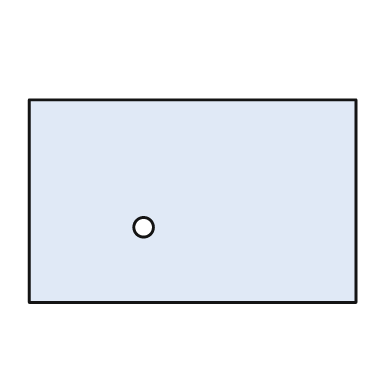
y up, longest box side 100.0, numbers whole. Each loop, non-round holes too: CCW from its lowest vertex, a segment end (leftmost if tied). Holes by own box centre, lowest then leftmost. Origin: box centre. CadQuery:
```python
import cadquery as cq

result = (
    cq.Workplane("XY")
    .moveTo(-50.0, -31.0)
    .lineTo(50.0, -31.0)
    .lineTo(50.0, 31.0)
    .lineTo(-50.0, 31.0)
    .close()
    .moveTo(-15.0, -8.0)
    .circle(3.0)
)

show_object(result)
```